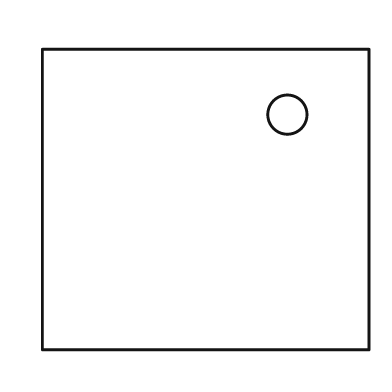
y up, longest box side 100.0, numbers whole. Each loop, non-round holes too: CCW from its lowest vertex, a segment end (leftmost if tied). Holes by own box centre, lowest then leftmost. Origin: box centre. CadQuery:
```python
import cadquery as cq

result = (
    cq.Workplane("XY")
    .moveTo(-50.0, -46.0)
    .lineTo(50.0, -46.0)
    .lineTo(50.0, 46.0)
    .lineTo(-50.0, 46.0)
    .close()
    .moveTo(25.0, 26.0)
    .circle(6.0)
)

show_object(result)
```